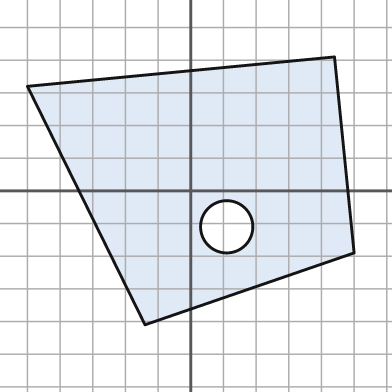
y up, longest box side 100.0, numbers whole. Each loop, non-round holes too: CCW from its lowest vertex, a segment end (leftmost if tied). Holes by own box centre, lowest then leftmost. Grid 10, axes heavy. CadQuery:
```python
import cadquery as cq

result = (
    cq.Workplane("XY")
    .moveTo(-14.0, -41.0)
    .lineTo(50.0, -19.0)
    .lineTo(44.0, 41.0)
    .lineTo(-50.0, 32.0)
    .close()
    .moveTo(11.0, -11.0)
    .circle(8.0)
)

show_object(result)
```